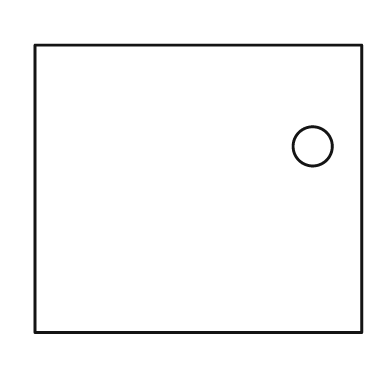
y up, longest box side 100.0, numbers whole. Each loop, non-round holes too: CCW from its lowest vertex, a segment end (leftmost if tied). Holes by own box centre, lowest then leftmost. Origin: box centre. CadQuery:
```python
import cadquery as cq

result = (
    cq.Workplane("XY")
    .moveTo(-50.0, -44.0)
    .lineTo(50.0, -44.0)
    .lineTo(50.0, 44.0)
    .lineTo(-50.0, 44.0)
    .close()
    .moveTo(35.0, 13.0)
    .circle(6.0)
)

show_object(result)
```